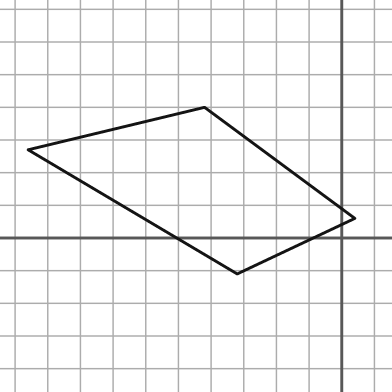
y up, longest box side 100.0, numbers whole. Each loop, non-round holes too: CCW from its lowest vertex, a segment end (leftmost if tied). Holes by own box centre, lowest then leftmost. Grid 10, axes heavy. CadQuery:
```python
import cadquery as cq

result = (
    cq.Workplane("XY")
    .moveTo(-32.0, -11.0)
    .lineTo(4.0, 6.0)
    .lineTo(-42.0, 40.0)
    .lineTo(-96.0, 27.0)
    .close()
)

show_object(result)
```